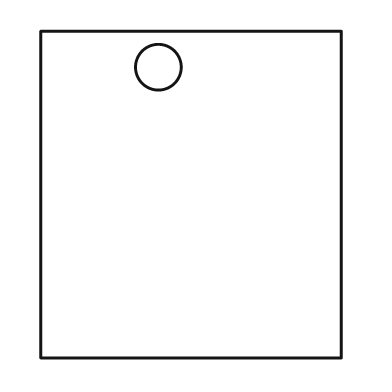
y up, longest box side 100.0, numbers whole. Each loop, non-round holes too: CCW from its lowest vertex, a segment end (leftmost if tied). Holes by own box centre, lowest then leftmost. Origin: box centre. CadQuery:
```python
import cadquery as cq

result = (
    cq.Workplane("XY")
    .moveTo(-46.0, -50.0)
    .lineTo(46.0, -50.0)
    .lineTo(46.0, 50.0)
    .lineTo(-46.0, 50.0)
    .close()
    .moveTo(-10.0, 39.0)
    .circle(7.0)
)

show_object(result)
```